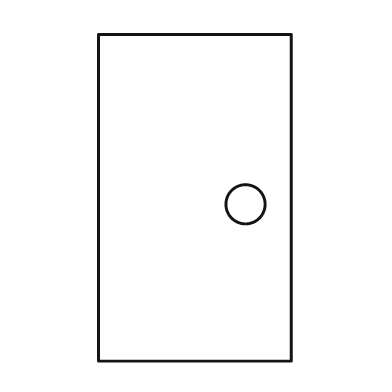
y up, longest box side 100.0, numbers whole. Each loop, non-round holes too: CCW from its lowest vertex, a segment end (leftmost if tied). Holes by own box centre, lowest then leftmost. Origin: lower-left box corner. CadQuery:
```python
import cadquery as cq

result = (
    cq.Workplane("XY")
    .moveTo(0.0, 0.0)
    .lineTo(59.0, 0.0)
    .lineTo(59.0, 100.0)
    .lineTo(0.0, 100.0)
    .close()
    .moveTo(45.0, 48.0)
    .circle(6.0)
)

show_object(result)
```